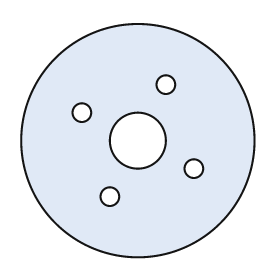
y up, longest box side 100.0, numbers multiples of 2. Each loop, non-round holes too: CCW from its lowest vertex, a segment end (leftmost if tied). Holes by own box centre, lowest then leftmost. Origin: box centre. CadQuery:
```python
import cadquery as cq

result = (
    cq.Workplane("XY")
    .moveTo(0.0, 0.0)
    .circle(50.0)
    .moveTo(-12.0, -24.0)
    .circle(4.0)
    .moveTo(24.0, -12.0)
    .circle(4.0)
    .moveTo(0.0, 0.0)
    .circle(12.0)
    .moveTo(-24.0, 12.0)
    .circle(4.0)
    .moveTo(12.0, 24.0)
    .circle(4.0)
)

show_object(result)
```